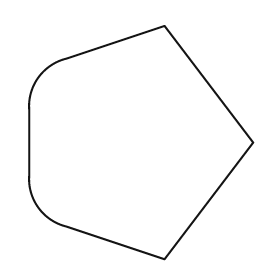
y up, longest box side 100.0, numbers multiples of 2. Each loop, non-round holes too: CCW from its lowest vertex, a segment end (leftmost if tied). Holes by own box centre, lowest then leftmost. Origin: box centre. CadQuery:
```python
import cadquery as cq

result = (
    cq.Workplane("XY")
    .moveTo(10.0, -50.0)
    .lineTo(48.0, 0.0)
    .lineTo(10.0, 50.0)
    .lineTo(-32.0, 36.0)
    .threePointArc((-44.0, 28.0), (-48.0, 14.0))
    .lineTo(-48.0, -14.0)
    .threePointArc((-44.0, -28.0), (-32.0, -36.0))
    .close()
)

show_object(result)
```